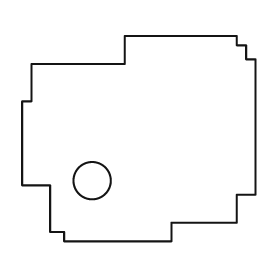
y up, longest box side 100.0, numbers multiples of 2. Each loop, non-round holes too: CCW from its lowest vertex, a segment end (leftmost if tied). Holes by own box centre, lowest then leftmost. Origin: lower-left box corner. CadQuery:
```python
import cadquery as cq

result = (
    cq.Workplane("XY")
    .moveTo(18.0, 0.0)
    .lineTo(64.0, 0.0)
    .lineTo(64.0, 8.0)
    .lineTo(92.0, 8.0)
    .lineTo(92.0, 20.0)
    .lineTo(100.0, 20.0)
    .lineTo(100.0, 78.0)
    .lineTo(96.0, 78.0)
    .lineTo(96.0, 84.0)
    .lineTo(92.0, 84.0)
    .lineTo(92.0, 88.0)
    .lineTo(44.0, 88.0)
    .lineTo(44.0, 76.0)
    .lineTo(4.0, 76.0)
    .lineTo(4.0, 60.0)
    .lineTo(0.0, 60.0)
    .lineTo(0.0, 24.0)
    .lineTo(12.0, 24.0)
    .lineTo(12.0, 4.0)
    .lineTo(18.0, 4.0)
    .close()
    .moveTo(30.0, 26.0)
    .circle(8.0)
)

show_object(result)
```